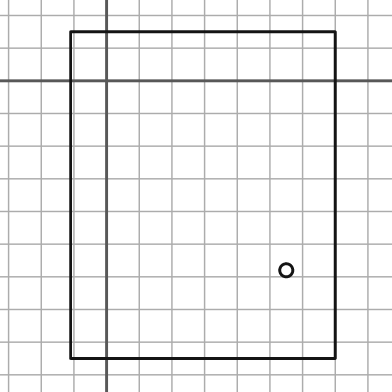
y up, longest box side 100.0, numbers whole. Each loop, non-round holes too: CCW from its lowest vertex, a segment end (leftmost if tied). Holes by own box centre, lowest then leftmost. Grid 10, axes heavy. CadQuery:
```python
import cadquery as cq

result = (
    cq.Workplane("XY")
    .moveTo(-11.0, -85.0)
    .lineTo(70.0, -85.0)
    .lineTo(70.0, 15.0)
    .lineTo(-11.0, 15.0)
    .close()
    .moveTo(55.0, -58.0)
    .circle(2.0)
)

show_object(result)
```